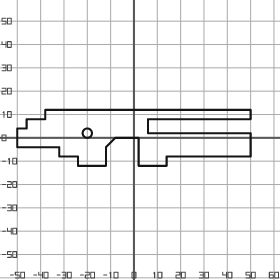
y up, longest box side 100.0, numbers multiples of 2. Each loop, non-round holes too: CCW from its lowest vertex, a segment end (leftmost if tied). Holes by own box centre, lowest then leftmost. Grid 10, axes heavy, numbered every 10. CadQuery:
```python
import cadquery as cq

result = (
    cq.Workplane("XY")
    .moveTo(-24.0, -12.0)
    .lineTo(-12.0, -12.0)
    .lineTo(-12.0, -4.0)
    .lineTo(-8.0, 0.0)
    .lineTo(2.0, 0.0)
    .lineTo(2.0, -12.0)
    .lineTo(14.0, -12.0)
    .lineTo(14.0, -8.0)
    .lineTo(50.0, -8.0)
    .lineTo(50.0, 2.0)
    .lineTo(6.0, 2.0)
    .lineTo(6.0, 8.0)
    .lineTo(50.0, 8.0)
    .lineTo(50.0, 12.0)
    .lineTo(-38.0, 12.0)
    .lineTo(-38.0, 8.0)
    .lineTo(-46.0, 8.0)
    .lineTo(-46.0, 4.0)
    .lineTo(-50.0, 4.0)
    .lineTo(-50.0, -4.0)
    .lineTo(-32.0, -4.0)
    .lineTo(-32.0, -8.0)
    .lineTo(-24.0, -8.0)
    .close()
    .moveTo(-20.0, 2.0)
    .circle(2.0)
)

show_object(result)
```